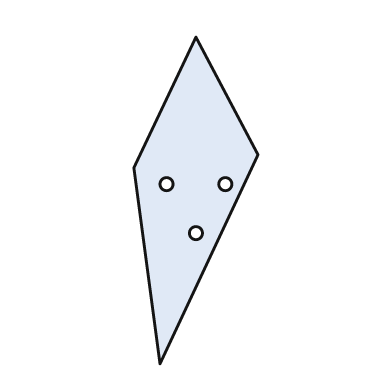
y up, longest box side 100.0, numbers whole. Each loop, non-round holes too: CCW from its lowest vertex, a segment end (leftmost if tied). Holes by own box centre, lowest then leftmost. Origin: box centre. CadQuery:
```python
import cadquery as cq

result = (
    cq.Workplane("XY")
    .moveTo(-11.0, -50.0)
    .lineTo(19.0, 14.0)
    .lineTo(0.0, 50.0)
    .lineTo(-19.0, 10.0)
    .close()
    .moveTo(0.0, -10.0)
    .circle(2.0)
    .moveTo(-9.0, 5.0)
    .circle(2.0)
    .moveTo(9.0, 5.0)
    .circle(2.0)
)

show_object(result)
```